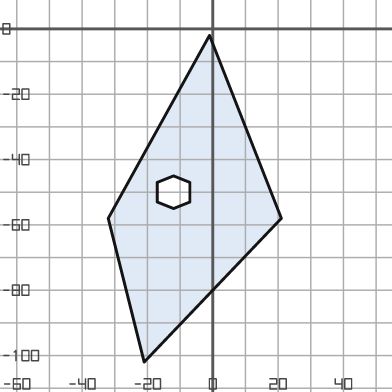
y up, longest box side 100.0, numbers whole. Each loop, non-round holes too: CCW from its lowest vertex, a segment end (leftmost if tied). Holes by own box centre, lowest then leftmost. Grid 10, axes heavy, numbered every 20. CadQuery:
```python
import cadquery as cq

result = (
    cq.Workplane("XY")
    .moveTo(-21.0, -102.0)
    .lineTo(21.0, -58.0)
    .lineTo(-1.0, -2.0)
    .lineTo(-32.0, -58.0)
    .close()
    .moveTo(-12.0, -55.0)
    .lineTo(-7.0, -53.0)
    .lineTo(-7.0, -47.0)
    .lineTo(-12.0, -45.0)
    .lineTo(-17.0, -47.0)
    .lineTo(-17.0, -53.0)
    .close()
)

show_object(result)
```